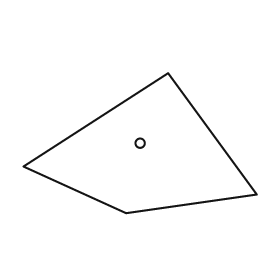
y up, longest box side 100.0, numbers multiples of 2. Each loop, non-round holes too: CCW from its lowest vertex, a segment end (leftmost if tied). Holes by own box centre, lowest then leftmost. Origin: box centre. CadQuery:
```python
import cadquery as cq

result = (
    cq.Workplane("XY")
    .moveTo(-6.0, -30.0)
    .lineTo(50.0, -22.0)
    .lineTo(12.0, 30.0)
    .lineTo(-50.0, -10.0)
    .close()
    .moveTo(0.0, 0.0)
    .circle(2.0)
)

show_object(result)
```